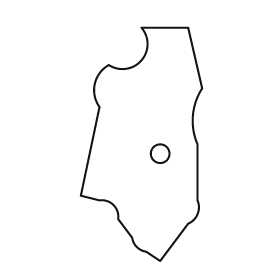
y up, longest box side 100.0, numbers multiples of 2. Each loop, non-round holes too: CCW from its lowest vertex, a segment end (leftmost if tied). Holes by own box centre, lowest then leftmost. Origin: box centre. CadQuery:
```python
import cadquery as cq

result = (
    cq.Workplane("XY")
    .moveTo(8.0, -50.0)
    .lineTo(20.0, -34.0)
    .threePointArc((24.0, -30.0), (24.0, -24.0))
    .lineTo(24.0, 0.0)
    .threePointArc((22.0, 12.0), (26.0, 24.0))
    .lineTo(20.0, 50.0)
    .lineTo(0.0, 50.0)
    .threePointArc((0.0, 36.0), (-14.0, 34.0))
    .threePointArc((-20.0, 26.0), (-18.0, 16.0))
    .lineTo(-26.0, -22.0)
    .lineTo(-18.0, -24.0)
    .threePointArc((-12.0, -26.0), (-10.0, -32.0))
    .lineTo(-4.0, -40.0)
    .threePointArc((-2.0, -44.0), (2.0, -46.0))
    .close()
    .moveTo(8.0, -4.0)
    .circle(4.0)
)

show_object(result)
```